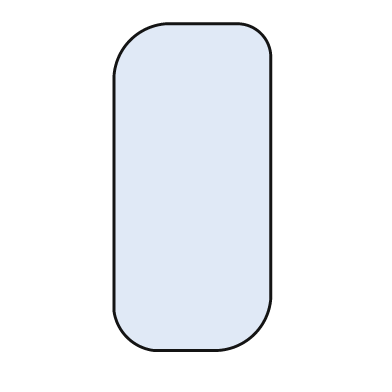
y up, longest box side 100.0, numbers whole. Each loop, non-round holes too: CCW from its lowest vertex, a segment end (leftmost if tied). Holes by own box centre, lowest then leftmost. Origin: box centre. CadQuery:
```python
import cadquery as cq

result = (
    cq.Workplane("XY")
    .moveTo(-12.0, -50.0)
    .lineTo(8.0, -50.0)
    .threePointArc((19.0, -45.0), (24.0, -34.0))
    .lineTo(24.0, 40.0)
    .threePointArc((21.0, 47.0), (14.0, 50.0))
    .lineTo(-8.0, 50.0)
    .threePointArc((-19.0, 45.0), (-24.0, 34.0))
    .lineTo(-24.0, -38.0)
    .threePointArc((-20.0, -46.0), (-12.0, -50.0))
    .close()
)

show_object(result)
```